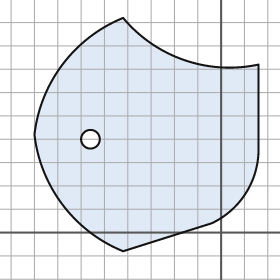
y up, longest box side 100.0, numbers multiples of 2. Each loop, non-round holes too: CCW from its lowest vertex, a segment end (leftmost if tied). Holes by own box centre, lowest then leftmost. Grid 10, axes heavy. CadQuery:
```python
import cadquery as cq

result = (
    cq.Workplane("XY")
    .moveTo(-42.0, -8.0)
    .lineTo(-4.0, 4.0)
    .threePointArc((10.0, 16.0), (16.0, 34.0))
    .lineTo(16.0, 72.0)
    .threePointArc((-16.0, 74.0), (-42.0, 92.0))
    .threePointArc((-68.0, 72.0), (-80.0, 42.0))
    .threePointArc((-68.0, 12.0), (-42.0, -8.0))
    .close()
    .moveTo(-56.0, 40.0)
    .circle(4.0)
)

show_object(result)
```